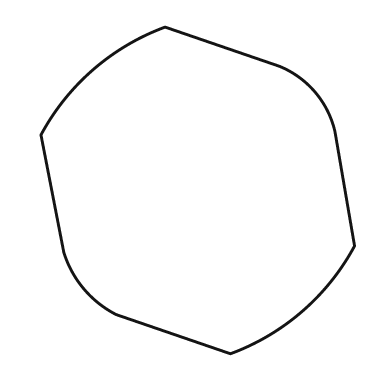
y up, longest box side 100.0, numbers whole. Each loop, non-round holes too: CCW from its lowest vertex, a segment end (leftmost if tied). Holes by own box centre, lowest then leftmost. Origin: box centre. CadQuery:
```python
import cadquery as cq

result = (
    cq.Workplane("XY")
    .moveTo(10.0, -50.0)
    .threePointArc((32.0, -37.0), (48.0, -17.0))
    .lineTo(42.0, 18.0)
    .threePointArc((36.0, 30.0), (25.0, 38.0))
    .lineTo(-10.0, 50.0)
    .threePointArc((-32.0, 37.0), (-48.0, 17.0))
    .lineTo(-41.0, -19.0)
    .threePointArc((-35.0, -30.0), (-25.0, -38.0))
    .close()
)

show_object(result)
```